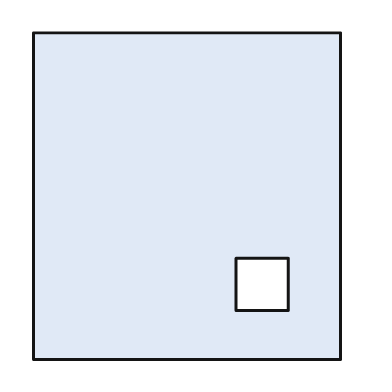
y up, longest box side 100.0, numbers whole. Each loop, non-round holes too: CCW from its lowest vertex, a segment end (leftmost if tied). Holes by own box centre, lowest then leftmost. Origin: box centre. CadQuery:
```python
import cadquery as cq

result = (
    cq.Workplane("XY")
    .moveTo(-47.0, -50.0)
    .lineTo(47.0, -50.0)
    .lineTo(47.0, 50.0)
    .lineTo(-47.0, 50.0)
    .close()
    .moveTo(15.0, -35.0)
    .lineTo(31.0, -35.0)
    .lineTo(31.0, -19.0)
    .lineTo(15.0, -19.0)
    .close()
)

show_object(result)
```